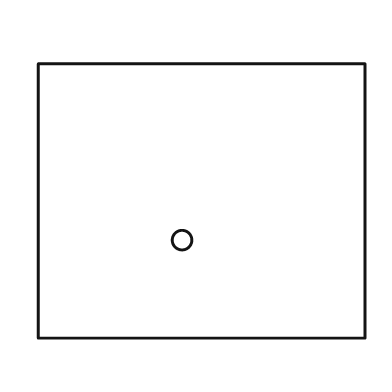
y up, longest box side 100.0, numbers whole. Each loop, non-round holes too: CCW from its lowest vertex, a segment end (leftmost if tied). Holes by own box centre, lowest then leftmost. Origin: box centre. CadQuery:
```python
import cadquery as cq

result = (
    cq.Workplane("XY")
    .moveTo(-50.0, -42.0)
    .lineTo(50.0, -42.0)
    .lineTo(50.0, 42.0)
    .lineTo(-50.0, 42.0)
    .close()
    .moveTo(-6.0, -12.0)
    .circle(3.0)
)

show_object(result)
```